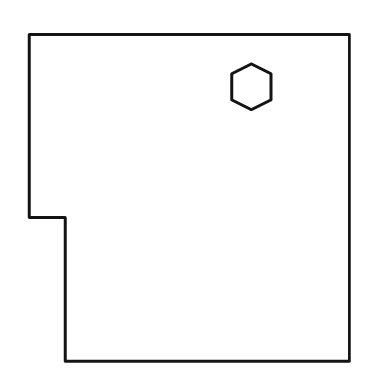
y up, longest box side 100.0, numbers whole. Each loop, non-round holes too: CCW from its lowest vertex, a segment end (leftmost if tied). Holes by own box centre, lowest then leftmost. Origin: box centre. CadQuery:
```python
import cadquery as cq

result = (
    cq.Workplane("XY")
    .moveTo(-38.0, -50.0)
    .lineTo(49.0, -50.0)
    .lineTo(49.0, 50.0)
    .lineTo(-49.0, 50.0)
    .lineTo(-49.0, -6.0)
    .lineTo(-38.0, -6.0)
    .close()
    .moveTo(19.0, 27.0)
    .lineTo(25.0, 30.0)
    .lineTo(25.0, 38.0)
    .lineTo(19.0, 41.0)
    .lineTo(13.0, 38.0)
    .lineTo(13.0, 30.0)
    .close()
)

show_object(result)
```